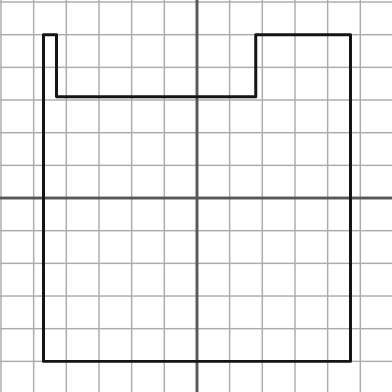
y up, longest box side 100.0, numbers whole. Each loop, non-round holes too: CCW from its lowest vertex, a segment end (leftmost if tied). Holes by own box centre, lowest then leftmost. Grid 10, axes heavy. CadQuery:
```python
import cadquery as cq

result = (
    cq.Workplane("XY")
    .moveTo(-47.0, -50.0)
    .lineTo(47.0, -50.0)
    .lineTo(47.0, 50.0)
    .lineTo(18.0, 50.0)
    .lineTo(18.0, 31.0)
    .lineTo(-43.0, 31.0)
    .lineTo(-43.0, 50.0)
    .lineTo(-47.0, 50.0)
    .close()
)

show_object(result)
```